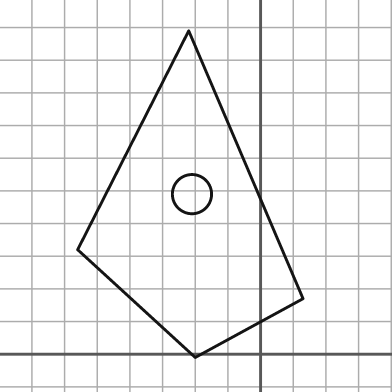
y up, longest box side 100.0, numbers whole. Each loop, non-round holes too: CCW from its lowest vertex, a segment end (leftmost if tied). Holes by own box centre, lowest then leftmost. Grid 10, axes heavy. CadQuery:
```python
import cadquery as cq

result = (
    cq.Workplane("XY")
    .moveTo(-20.0, -1.0)
    .lineTo(13.0, 17.0)
    .lineTo(-22.0, 99.0)
    .lineTo(-56.0, 32.0)
    .close()
    .moveTo(-21.0, 49.0)
    .circle(6.0)
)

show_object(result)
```